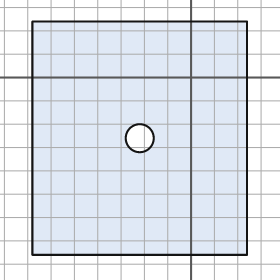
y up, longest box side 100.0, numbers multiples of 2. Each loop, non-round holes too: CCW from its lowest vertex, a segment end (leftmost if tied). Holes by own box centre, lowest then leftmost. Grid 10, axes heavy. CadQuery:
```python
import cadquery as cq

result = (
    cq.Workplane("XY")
    .moveTo(-68.0, -76.0)
    .lineTo(24.0, -76.0)
    .lineTo(24.0, 24.0)
    .lineTo(-68.0, 24.0)
    .close()
    .moveTo(-22.0, -26.0)
    .circle(6.0)
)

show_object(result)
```